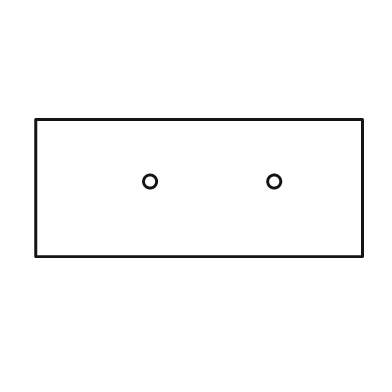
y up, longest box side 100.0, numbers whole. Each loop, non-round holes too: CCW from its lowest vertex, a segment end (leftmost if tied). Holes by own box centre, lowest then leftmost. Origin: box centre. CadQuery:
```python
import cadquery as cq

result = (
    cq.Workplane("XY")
    .moveTo(-50.0, -21.0)
    .lineTo(50.0, -21.0)
    .lineTo(50.0, 21.0)
    .lineTo(-50.0, 21.0)
    .close()
    .moveTo(-15.0, 2.0)
    .circle(2.0)
    .moveTo(23.0, 2.0)
    .circle(2.0)
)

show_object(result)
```